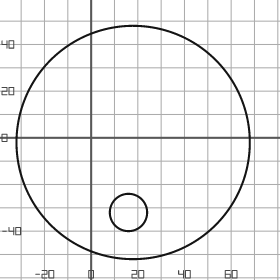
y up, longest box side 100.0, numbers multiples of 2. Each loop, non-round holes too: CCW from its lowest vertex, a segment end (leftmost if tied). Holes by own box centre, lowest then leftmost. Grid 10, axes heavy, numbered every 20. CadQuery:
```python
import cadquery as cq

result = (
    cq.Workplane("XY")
    .moveTo(18.0, -2.0)
    .circle(50.0)
    .moveTo(16.0, -32.0)
    .circle(8.0)
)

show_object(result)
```